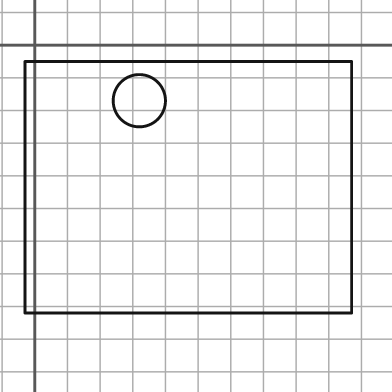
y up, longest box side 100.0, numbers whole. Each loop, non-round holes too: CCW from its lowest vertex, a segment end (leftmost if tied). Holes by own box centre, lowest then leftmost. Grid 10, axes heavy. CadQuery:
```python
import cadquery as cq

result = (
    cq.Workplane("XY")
    .moveTo(-3.0, -82.0)
    .lineTo(97.0, -82.0)
    .lineTo(97.0, -5.0)
    .lineTo(-3.0, -5.0)
    .close()
    .moveTo(32.0, -17.0)
    .circle(8.0)
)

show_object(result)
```